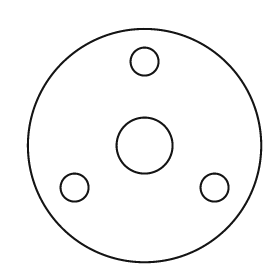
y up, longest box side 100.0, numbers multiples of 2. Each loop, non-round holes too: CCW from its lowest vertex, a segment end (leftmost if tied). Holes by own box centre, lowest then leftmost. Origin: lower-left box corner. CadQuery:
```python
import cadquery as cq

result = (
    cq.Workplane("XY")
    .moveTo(50.0, 50.0)
    .circle(50.0)
    .moveTo(20.0, 32.0)
    .circle(6.0)
    .moveTo(80.0, 32.0)
    .circle(6.0)
    .moveTo(50.0, 50.0)
    .circle(12.0)
    .moveTo(50.0, 86.0)
    .circle(6.0)
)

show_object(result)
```